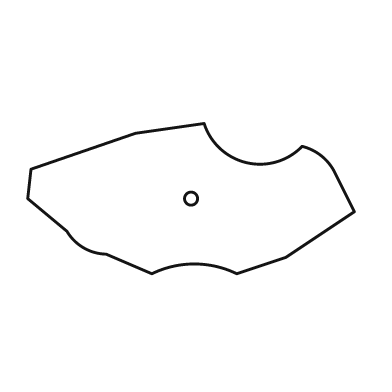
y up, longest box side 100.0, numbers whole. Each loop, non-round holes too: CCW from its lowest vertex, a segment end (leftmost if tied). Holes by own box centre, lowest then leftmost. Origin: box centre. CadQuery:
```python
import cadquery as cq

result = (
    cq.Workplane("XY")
    .moveTo(-12.0, -23.0)
    .threePointArc((1.0, -20.0), (14.0, -23.0))
    .lineTo(29.0, -18.0)
    .lineTo(50.0, -4.0)
    .lineTo(44.0, 8.0)
    .threePointArc((40.0, 13.0), (34.0, 16.0))
    .threePointArc((17.0, 11.0), (4.0, 23.0))
    .lineTo(-17.0, 20.0)
    .lineTo(-49.0, 9.0)
    .lineTo(-50.0, 0.0)
    .lineTo(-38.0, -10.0)
    .threePointArc((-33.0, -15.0), (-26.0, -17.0))
    .close()
    .moveTo(0.0, 0.0)
    .circle(2.0)
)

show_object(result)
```